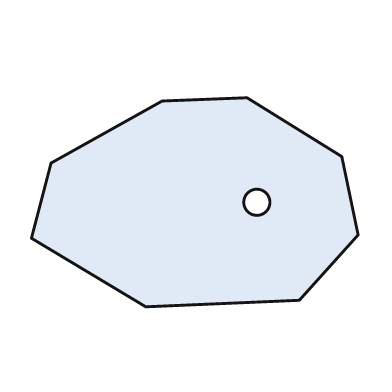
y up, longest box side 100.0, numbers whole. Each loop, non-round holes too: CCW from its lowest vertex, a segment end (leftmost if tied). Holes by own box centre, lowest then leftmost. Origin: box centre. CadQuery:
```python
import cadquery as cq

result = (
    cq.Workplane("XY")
    .moveTo(-15.0, -32.0)
    .lineTo(32.0, -30.0)
    .lineTo(50.0, -10.0)
    .lineTo(45.0, 14.0)
    .lineTo(16.0, 32.0)
    .lineTo(-10.0, 31.0)
    .lineTo(-44.0, 12.0)
    .lineTo(-50.0, -11.0)
    .close()
    .moveTo(19.0, 0.0)
    .circle(4.0)
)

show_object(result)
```